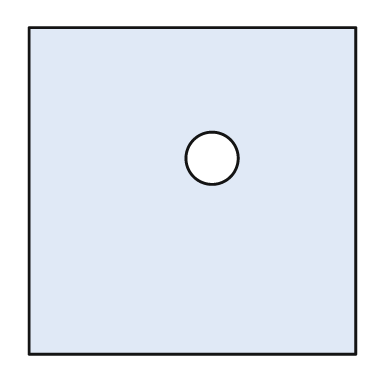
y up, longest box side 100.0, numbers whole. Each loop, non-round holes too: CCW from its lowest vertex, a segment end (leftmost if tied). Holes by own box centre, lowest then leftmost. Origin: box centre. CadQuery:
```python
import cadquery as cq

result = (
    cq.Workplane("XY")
    .moveTo(-50.0, -50.0)
    .lineTo(50.0, -50.0)
    .lineTo(50.0, 50.0)
    .lineTo(-50.0, 50.0)
    .close()
    .moveTo(6.0, 10.0)
    .circle(8.0)
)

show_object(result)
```